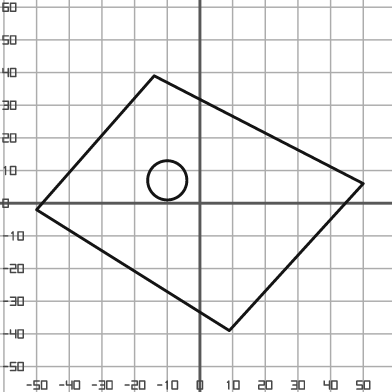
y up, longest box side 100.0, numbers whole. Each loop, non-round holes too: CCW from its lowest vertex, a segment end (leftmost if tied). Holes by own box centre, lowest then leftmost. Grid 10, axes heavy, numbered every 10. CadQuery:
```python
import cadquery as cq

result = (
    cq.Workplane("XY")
    .moveTo(9.0, -39.0)
    .lineTo(50.0, 6.0)
    .lineTo(-14.0, 39.0)
    .lineTo(-50.0, -2.0)
    .close()
    .moveTo(-10.0, 7.0)
    .circle(6.0)
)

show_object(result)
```